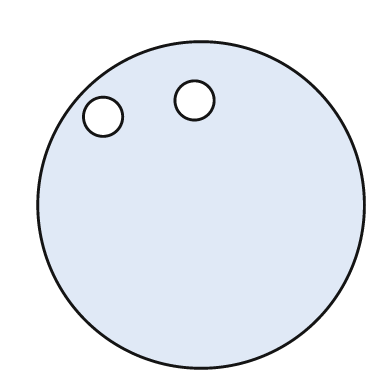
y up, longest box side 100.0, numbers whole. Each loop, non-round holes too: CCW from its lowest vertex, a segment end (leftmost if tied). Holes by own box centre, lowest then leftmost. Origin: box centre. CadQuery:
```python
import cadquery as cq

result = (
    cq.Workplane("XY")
    .moveTo(0.0, 0.0)
    .circle(50.0)
    .moveTo(-30.0, 27.0)
    .circle(6.0)
    .moveTo(-2.0, 32.0)
    .circle(6.0)
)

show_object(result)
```